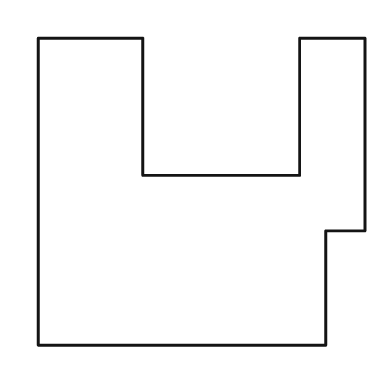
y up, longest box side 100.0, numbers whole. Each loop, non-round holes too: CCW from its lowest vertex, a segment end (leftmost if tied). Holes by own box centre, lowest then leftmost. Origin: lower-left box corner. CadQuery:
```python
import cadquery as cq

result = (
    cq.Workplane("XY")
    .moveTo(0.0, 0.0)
    .lineTo(88.0, 0.0)
    .lineTo(88.0, 35.0)
    .lineTo(100.0, 35.0)
    .lineTo(100.0, 94.0)
    .lineTo(80.0, 94.0)
    .lineTo(80.0, 52.0)
    .lineTo(32.0, 52.0)
    .lineTo(32.0, 94.0)
    .lineTo(0.0, 94.0)
    .close()
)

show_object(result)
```